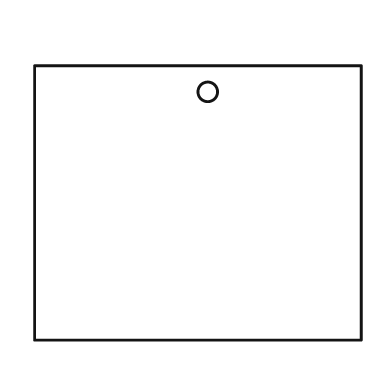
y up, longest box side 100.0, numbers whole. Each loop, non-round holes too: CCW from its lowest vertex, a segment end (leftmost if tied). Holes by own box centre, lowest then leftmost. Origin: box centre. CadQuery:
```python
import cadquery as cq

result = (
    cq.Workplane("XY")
    .moveTo(-50.0, -42.0)
    .lineTo(50.0, -42.0)
    .lineTo(50.0, 42.0)
    .lineTo(-50.0, 42.0)
    .close()
    .moveTo(3.0, 34.0)
    .circle(3.0)
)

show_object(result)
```